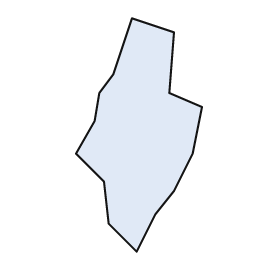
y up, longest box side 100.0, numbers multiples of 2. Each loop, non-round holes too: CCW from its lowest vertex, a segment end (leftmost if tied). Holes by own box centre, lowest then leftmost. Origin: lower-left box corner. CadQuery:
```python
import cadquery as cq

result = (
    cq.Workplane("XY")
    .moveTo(26.0, 0.0)
    .lineTo(34.0, 16.0)
    .lineTo(42.0, 26.0)
    .lineTo(50.0, 42.0)
    .lineTo(54.0, 62.0)
    .lineTo(40.0, 68.0)
    .lineTo(42.0, 94.0)
    .lineTo(24.0, 100.0)
    .lineTo(16.0, 76.0)
    .lineTo(10.0, 68.0)
    .lineTo(8.0, 56.0)
    .lineTo(0.0, 42.0)
    .lineTo(12.0, 30.0)
    .lineTo(14.0, 12.0)
    .close()
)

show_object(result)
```